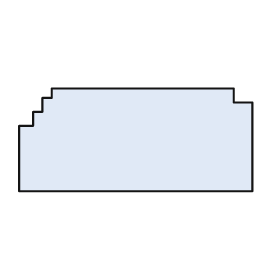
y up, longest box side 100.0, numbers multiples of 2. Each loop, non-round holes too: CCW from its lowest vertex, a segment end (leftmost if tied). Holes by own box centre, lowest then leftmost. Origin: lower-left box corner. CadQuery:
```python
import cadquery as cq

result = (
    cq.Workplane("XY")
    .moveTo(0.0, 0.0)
    .lineTo(100.0, 0.0)
    .lineTo(100.0, 38.0)
    .lineTo(92.0, 38.0)
    .lineTo(92.0, 44.0)
    .lineTo(14.0, 44.0)
    .lineTo(14.0, 40.0)
    .lineTo(10.0, 40.0)
    .lineTo(10.0, 34.0)
    .lineTo(6.0, 34.0)
    .lineTo(6.0, 28.0)
    .lineTo(0.0, 28.0)
    .close()
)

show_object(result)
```